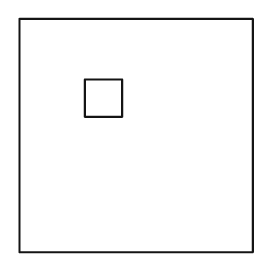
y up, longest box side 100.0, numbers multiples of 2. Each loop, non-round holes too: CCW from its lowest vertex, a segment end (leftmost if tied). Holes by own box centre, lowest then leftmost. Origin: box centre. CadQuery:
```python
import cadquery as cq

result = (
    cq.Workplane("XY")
    .moveTo(-50.0, -50.0)
    .lineTo(50.0, -50.0)
    .lineTo(50.0, 50.0)
    .lineTo(-50.0, 50.0)
    .close()
    .moveTo(-22.0, 8.0)
    .lineTo(-6.0, 8.0)
    .lineTo(-6.0, 24.0)
    .lineTo(-22.0, 24.0)
    .close()
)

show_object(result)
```